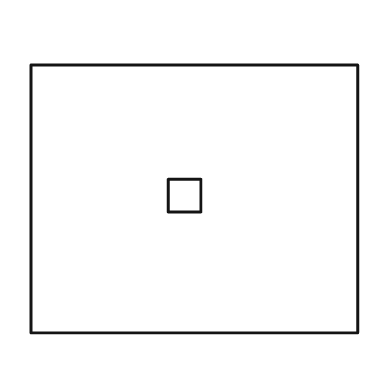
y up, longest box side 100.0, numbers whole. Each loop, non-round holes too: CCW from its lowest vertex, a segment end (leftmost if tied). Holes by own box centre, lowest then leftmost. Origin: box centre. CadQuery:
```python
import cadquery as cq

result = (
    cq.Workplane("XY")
    .moveTo(-50.0, -41.0)
    .lineTo(50.0, -41.0)
    .lineTo(50.0, 41.0)
    .lineTo(-50.0, 41.0)
    .close()
    .moveTo(-8.0, -4.0)
    .lineTo(2.0, -4.0)
    .lineTo(2.0, 6.0)
    .lineTo(-8.0, 6.0)
    .close()
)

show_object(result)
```